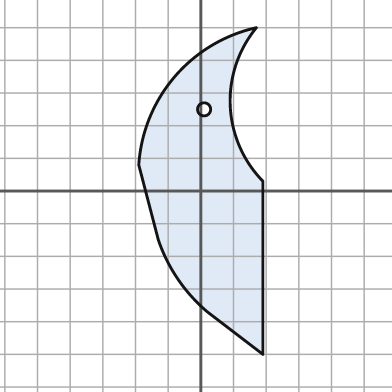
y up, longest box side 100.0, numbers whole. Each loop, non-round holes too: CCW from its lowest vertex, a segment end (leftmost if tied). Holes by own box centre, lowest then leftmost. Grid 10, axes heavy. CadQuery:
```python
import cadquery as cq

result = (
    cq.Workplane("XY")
    .moveTo(19.0, -50.0)
    .lineTo(19.0, 3.0)
    .threePointArc((9.0, 26.0), (17.0, 50.0))
    .threePointArc((-8.0, 35.0), (-19.0, 8.0))
    .lineTo(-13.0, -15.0)
    .threePointArc((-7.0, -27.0), (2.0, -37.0))
    .close()
    .moveTo(1.0, 25.0)
    .circle(2.0)
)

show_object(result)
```